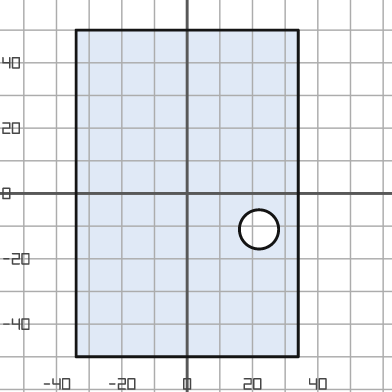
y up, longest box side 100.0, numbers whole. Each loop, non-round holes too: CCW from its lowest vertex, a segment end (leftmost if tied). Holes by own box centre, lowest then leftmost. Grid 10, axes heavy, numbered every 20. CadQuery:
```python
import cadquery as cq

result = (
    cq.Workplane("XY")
    .moveTo(-34.0, -50.0)
    .lineTo(34.0, -50.0)
    .lineTo(34.0, 50.0)
    .lineTo(-34.0, 50.0)
    .close()
    .moveTo(22.0, -11.0)
    .circle(6.0)
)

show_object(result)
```